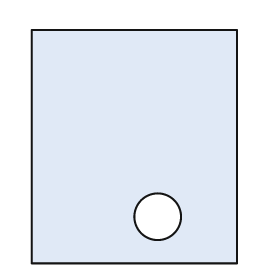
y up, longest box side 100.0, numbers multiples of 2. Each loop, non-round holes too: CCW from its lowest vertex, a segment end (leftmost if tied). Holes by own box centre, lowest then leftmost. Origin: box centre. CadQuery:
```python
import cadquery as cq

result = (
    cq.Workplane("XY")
    .moveTo(-44.0, -50.0)
    .lineTo(44.0, -50.0)
    .lineTo(44.0, 50.0)
    .lineTo(-44.0, 50.0)
    .close()
    .moveTo(10.0, -30.0)
    .circle(10.0)
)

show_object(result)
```